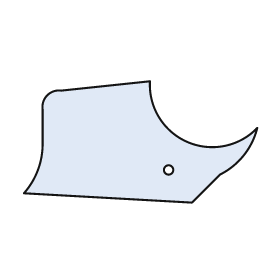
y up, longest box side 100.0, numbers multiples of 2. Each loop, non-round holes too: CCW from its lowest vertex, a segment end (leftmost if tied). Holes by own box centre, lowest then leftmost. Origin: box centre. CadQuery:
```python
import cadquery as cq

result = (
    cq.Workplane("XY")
    .moveTo(22.0, -26.0)
    .lineTo(34.0, -14.0)
    .threePointArc((44.0, -6.0), (50.0, 6.0))
    .threePointArc((20.0, 0.0), (4.0, 26.0))
    .lineTo(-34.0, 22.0)
    .threePointArc((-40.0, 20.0), (-42.0, 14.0))
    .lineTo(-42.0, 0.0)
    .threePointArc((-44.0, -12.0), (-50.0, -22.0))
    .close()
    .moveTo(12.0, -12.0)
    .circle(2.0)
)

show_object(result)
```